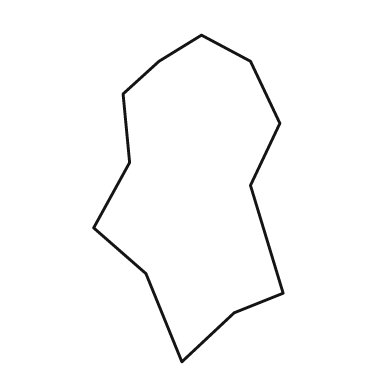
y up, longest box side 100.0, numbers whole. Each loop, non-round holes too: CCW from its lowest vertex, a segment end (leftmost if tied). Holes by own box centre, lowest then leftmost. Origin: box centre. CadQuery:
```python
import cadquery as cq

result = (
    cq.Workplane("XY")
    .moveTo(-2.0, -50.0)
    .lineTo(14.0, -35.0)
    .lineTo(29.0, -29.0)
    .lineTo(19.0, 4.0)
    .lineTo(28.0, 23.0)
    .lineTo(19.0, 42.0)
    .lineTo(4.0, 50.0)
    .lineTo(-9.0, 42.0)
    .lineTo(-20.0, 32.0)
    .lineTo(-18.0, 11.0)
    .lineTo(-29.0, -9.0)
    .lineTo(-13.0, -23.0)
    .close()
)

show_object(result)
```